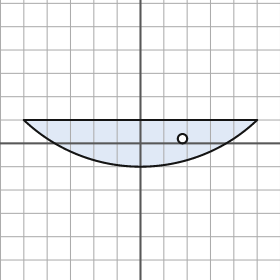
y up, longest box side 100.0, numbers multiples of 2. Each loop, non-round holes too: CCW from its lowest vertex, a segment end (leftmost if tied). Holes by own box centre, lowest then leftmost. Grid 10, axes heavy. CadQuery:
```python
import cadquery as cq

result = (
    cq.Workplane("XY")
    .moveTo(-50.0, 10.0)
    .threePointArc((0.0, -10.0), (50.0, 10.0))
    .close()
    .moveTo(18.0, 2.0)
    .circle(2.0)
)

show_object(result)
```